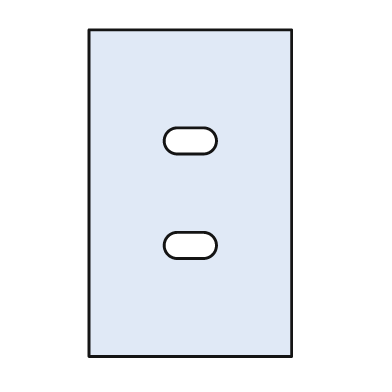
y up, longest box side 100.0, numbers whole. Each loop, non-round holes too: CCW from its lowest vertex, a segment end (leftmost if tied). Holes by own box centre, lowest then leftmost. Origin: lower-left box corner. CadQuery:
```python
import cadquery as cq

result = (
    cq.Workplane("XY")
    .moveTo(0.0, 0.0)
    .lineTo(62.0, 0.0)
    .lineTo(62.0, 100.0)
    .lineTo(0.0, 100.0)
    .close()
    .moveTo(27.0, 30.0)
    .lineTo(35.0, 30.0)
    .threePointArc((39.0, 34.0), (35.0, 38.0))
    .lineTo(27.0, 38.0)
    .threePointArc((23.0, 34.0), (27.0, 30.0))
    .close()
    .moveTo(27.0, 62.0)
    .lineTo(35.0, 62.0)
    .threePointArc((39.0, 66.0), (35.0, 70.0))
    .lineTo(27.0, 70.0)
    .threePointArc((23.0, 66.0), (27.0, 62.0))
    .close()
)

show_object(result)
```